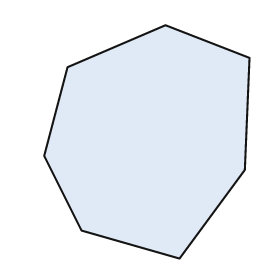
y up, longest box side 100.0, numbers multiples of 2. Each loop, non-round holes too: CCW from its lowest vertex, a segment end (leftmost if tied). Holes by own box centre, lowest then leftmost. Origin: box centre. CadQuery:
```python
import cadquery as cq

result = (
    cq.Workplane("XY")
    .moveTo(14.0, -50.0)
    .lineTo(42.0, -12.0)
    .lineTo(44.0, 36.0)
    .lineTo(8.0, 50.0)
    .lineTo(-34.0, 32.0)
    .lineTo(-44.0, -6.0)
    .lineTo(-28.0, -38.0)
    .close()
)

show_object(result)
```